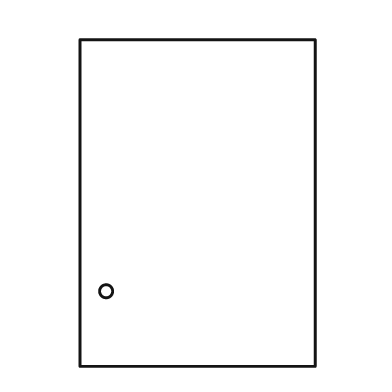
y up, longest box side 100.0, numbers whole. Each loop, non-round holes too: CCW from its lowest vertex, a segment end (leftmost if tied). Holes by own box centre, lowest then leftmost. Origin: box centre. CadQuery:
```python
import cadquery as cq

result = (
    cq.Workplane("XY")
    .moveTo(-36.0, -50.0)
    .lineTo(36.0, -50.0)
    .lineTo(36.0, 50.0)
    .lineTo(-36.0, 50.0)
    .close()
    .moveTo(-28.0, -27.0)
    .circle(2.0)
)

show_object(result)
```